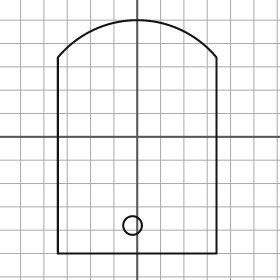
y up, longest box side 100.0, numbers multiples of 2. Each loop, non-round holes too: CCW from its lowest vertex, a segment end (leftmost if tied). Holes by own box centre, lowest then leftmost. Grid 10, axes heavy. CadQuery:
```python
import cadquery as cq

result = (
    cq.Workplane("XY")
    .moveTo(-34.0, -50.0)
    .lineTo(34.0, -50.0)
    .lineTo(34.0, 34.0)
    .threePointArc((0.0, 50.0), (-34.0, 34.0))
    .close()
    .moveTo(-2.0, -38.0)
    .circle(4.0)
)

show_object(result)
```